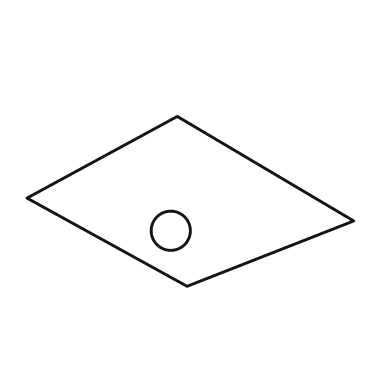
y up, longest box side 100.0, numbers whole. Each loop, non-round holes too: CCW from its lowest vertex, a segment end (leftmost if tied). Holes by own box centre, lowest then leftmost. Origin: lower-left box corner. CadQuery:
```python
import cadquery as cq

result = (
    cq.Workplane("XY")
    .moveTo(49.0, 0.0)
    .lineTo(100.0, 20.0)
    .lineTo(46.0, 52.0)
    .lineTo(0.0, 27.0)
    .close()
    .moveTo(44.0, 17.0)
    .circle(6.0)
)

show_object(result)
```